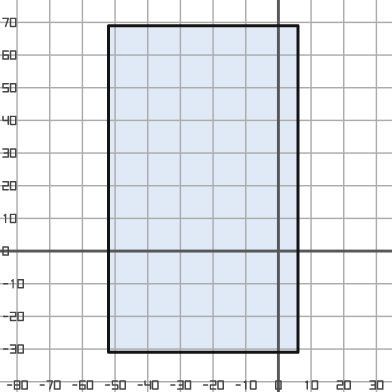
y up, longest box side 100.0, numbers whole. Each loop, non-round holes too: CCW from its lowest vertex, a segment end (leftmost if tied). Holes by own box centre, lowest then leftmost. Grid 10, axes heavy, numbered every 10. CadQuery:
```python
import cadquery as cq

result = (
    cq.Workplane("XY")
    .moveTo(-52.0, -31.0)
    .lineTo(6.0, -31.0)
    .lineTo(6.0, 69.0)
    .lineTo(-52.0, 69.0)
    .close()
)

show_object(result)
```